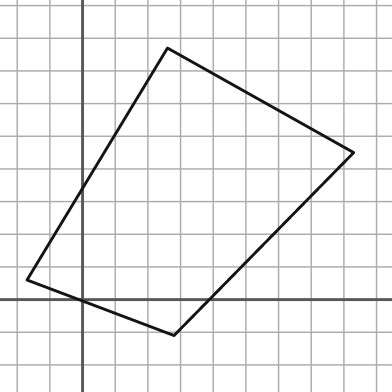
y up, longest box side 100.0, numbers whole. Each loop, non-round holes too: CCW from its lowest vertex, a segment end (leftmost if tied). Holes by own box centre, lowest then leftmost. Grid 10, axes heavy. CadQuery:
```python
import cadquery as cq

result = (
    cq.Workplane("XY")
    .moveTo(28.0, -11.0)
    .lineTo(83.0, 45.0)
    .lineTo(26.0, 77.0)
    .lineTo(-17.0, 6.0)
    .close()
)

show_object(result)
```